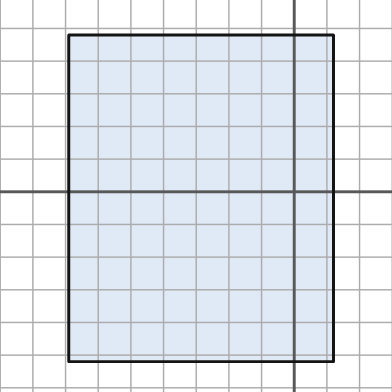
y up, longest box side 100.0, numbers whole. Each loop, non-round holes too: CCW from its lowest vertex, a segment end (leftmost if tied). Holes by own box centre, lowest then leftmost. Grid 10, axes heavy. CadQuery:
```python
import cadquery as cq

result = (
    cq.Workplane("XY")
    .moveTo(-69.0, -52.0)
    .lineTo(12.0, -52.0)
    .lineTo(12.0, 48.0)
    .lineTo(-69.0, 48.0)
    .close()
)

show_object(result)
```